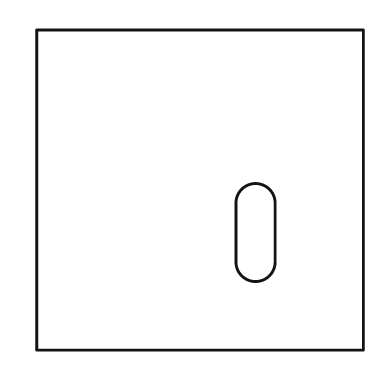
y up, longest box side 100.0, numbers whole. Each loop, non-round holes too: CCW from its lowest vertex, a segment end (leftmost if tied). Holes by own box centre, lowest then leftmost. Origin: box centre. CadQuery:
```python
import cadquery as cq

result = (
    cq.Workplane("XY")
    .moveTo(-50.0, -49.0)
    .lineTo(50.0, -49.0)
    .lineTo(50.0, 49.0)
    .lineTo(-50.0, 49.0)
    .close()
    .moveTo(11.0, -22.0)
    .threePointArc((17.0, -28.0), (23.0, -22.0))
    .lineTo(23.0, -4.0)
    .threePointArc((17.0, 2.0), (11.0, -4.0))
    .close()
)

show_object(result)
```